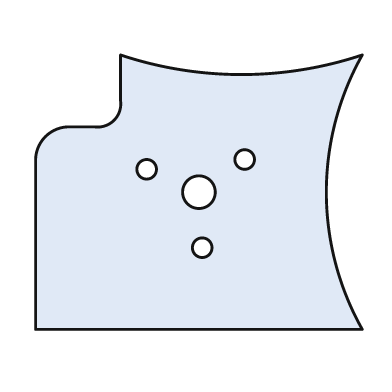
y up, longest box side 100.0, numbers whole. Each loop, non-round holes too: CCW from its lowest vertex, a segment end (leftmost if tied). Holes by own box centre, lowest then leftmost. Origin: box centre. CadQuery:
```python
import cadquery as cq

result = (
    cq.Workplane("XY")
    .moveTo(-50.0, -42.0)
    .lineTo(50.0, -42.0)
    .threePointArc((39.0, 0.0), (50.0, 42.0))
    .threePointArc((13.0, 36.0), (-24.0, 42.0))
    .lineTo(-24.0, 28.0)
    .threePointArc((-26.0, 22.0), (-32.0, 20.0))
    .lineTo(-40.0, 20.0)
    .threePointArc((-47.0, 17.0), (-50.0, 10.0))
    .close()
    .moveTo(1.0, -17.0)
    .circle(3.0)
    .moveTo(0.0, 0.0)
    .circle(5.0)
    .moveTo(-16.0, 7.0)
    .circle(3.0)
    .moveTo(14.0, 10.0)
    .circle(3.0)
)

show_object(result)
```